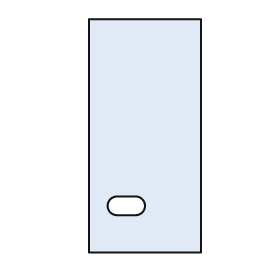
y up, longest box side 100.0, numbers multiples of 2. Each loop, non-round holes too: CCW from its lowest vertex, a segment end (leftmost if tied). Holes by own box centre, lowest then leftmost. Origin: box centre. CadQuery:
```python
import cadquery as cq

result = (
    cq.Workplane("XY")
    .moveTo(-24.0, -50.0)
    .lineTo(24.0, -50.0)
    .lineTo(24.0, 50.0)
    .lineTo(-24.0, 50.0)
    .close()
    .moveTo(-12.0, -34.0)
    .lineTo(-4.0, -34.0)
    .threePointArc((0.0, -30.0), (-4.0, -26.0))
    .lineTo(-12.0, -26.0)
    .threePointArc((-16.0, -30.0), (-12.0, -34.0))
    .close()
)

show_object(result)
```